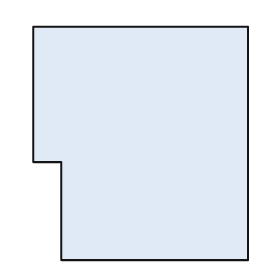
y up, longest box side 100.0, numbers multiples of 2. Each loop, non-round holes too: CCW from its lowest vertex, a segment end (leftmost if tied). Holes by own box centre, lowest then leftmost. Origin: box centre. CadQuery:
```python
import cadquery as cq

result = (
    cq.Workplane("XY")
    .moveTo(-34.0, -50.0)
    .lineTo(46.0, -50.0)
    .lineTo(46.0, 50.0)
    .lineTo(-46.0, 50.0)
    .lineTo(-46.0, -8.0)
    .lineTo(-34.0, -8.0)
    .close()
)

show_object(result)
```